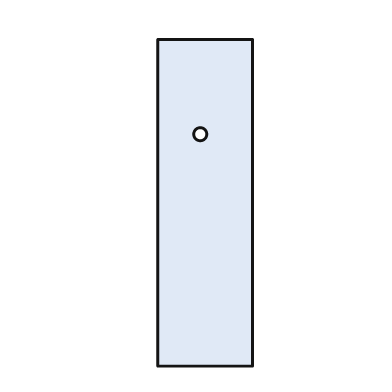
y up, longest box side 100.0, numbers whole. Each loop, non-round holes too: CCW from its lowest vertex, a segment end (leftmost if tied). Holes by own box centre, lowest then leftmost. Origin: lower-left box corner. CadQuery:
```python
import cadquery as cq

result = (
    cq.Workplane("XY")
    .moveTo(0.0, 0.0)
    .lineTo(29.0, 0.0)
    .lineTo(29.0, 100.0)
    .lineTo(0.0, 100.0)
    .close()
    .moveTo(13.0, 71.0)
    .circle(2.0)
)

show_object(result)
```